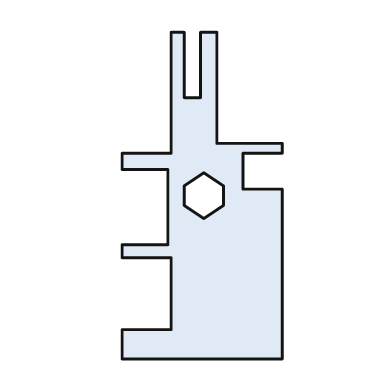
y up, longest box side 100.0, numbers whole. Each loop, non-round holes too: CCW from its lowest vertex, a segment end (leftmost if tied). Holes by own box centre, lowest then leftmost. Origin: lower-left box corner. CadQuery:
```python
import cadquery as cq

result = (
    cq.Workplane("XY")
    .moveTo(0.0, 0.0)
    .lineTo(49.0, 0.0)
    .lineTo(49.0, 52.0)
    .lineTo(37.0, 52.0)
    .lineTo(37.0, 63.0)
    .lineTo(49.0, 63.0)
    .lineTo(49.0, 66.0)
    .lineTo(29.0, 66.0)
    .lineTo(29.0, 100.0)
    .lineTo(24.0, 100.0)
    .lineTo(24.0, 80.0)
    .lineTo(19.0, 80.0)
    .lineTo(19.0, 100.0)
    .lineTo(15.0, 100.0)
    .lineTo(15.0, 63.0)
    .lineTo(0.0, 63.0)
    .lineTo(0.0, 58.0)
    .lineTo(14.0, 58.0)
    .lineTo(14.0, 35.0)
    .lineTo(0.0, 35.0)
    .lineTo(0.0, 31.0)
    .lineTo(15.0, 31.0)
    .lineTo(15.0, 9.0)
    .lineTo(0.0, 9.0)
    .close()
    .moveTo(25.0, 43.0)
    .lineTo(31.0, 47.0)
    .lineTo(31.0, 53.0)
    .lineTo(25.0, 57.0)
    .lineTo(19.0, 53.0)
    .lineTo(19.0, 47.0)
    .close()
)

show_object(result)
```